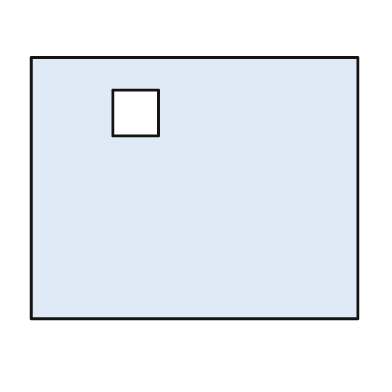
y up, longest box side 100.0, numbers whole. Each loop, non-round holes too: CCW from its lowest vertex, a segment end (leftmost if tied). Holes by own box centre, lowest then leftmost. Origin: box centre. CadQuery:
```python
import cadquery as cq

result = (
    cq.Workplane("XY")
    .moveTo(-50.0, -40.0)
    .lineTo(50.0, -40.0)
    .lineTo(50.0, 40.0)
    .lineTo(-50.0, 40.0)
    .close()
    .moveTo(-25.0, 16.0)
    .lineTo(-11.0, 16.0)
    .lineTo(-11.0, 30.0)
    .lineTo(-25.0, 30.0)
    .close()
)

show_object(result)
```